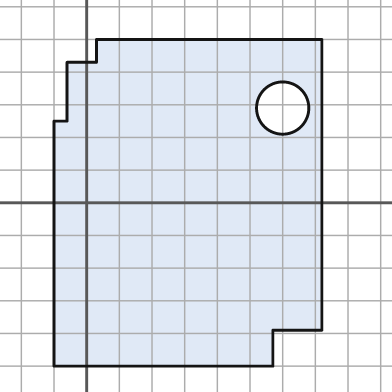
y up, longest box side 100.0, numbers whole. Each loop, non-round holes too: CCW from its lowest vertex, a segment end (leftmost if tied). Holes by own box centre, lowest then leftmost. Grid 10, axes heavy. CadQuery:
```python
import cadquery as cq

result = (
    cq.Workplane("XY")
    .moveTo(-10.0, -50.0)
    .lineTo(57.0, -50.0)
    .lineTo(57.0, -39.0)
    .lineTo(72.0, -39.0)
    .lineTo(72.0, 50.0)
    .lineTo(3.0, 50.0)
    .lineTo(3.0, 43.0)
    .lineTo(-6.0, 43.0)
    .lineTo(-6.0, 25.0)
    .lineTo(-10.0, 25.0)
    .close()
    .moveTo(60.0, 29.0)
    .circle(8.0)
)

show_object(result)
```